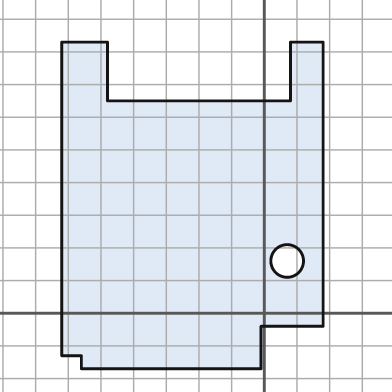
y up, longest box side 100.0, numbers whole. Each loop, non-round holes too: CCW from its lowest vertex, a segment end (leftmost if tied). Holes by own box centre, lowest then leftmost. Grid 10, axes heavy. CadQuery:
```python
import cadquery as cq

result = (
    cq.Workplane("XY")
    .moveTo(-56.0, -17.0)
    .lineTo(-1.0, -17.0)
    .lineTo(-1.0, -4.0)
    .lineTo(18.0, -4.0)
    .lineTo(18.0, 83.0)
    .lineTo(8.0, 83.0)
    .lineTo(8.0, 65.0)
    .lineTo(-48.0, 65.0)
    .lineTo(-48.0, 83.0)
    .lineTo(-62.0, 83.0)
    .lineTo(-62.0, -13.0)
    .lineTo(-56.0, -13.0)
    .close()
    .moveTo(7.0, 16.0)
    .circle(5.0)
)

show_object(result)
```